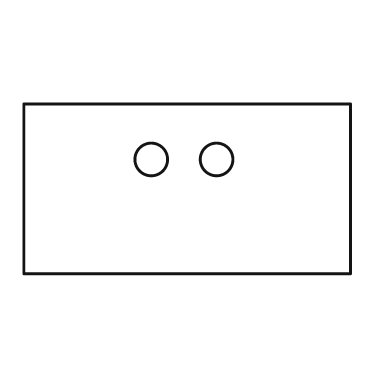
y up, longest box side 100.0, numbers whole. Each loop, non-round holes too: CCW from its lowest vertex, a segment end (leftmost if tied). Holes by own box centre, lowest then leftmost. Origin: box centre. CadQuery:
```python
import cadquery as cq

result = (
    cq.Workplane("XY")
    .moveTo(-50.0, -26.0)
    .lineTo(50.0, -26.0)
    .lineTo(50.0, 26.0)
    .lineTo(-50.0, 26.0)
    .close()
    .moveTo(-11.0, 9.0)
    .circle(5.0)
    .moveTo(9.0, 9.0)
    .circle(5.0)
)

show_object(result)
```